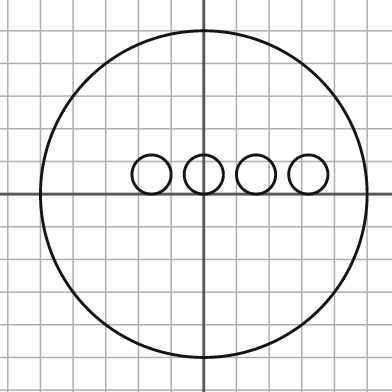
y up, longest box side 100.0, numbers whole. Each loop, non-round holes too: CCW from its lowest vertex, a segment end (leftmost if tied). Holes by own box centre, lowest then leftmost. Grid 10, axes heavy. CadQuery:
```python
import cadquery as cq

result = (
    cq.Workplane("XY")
    .moveTo(0.0, 0.0)
    .circle(50.0)
    .moveTo(-16.0, 6.0)
    .circle(6.0)
    .moveTo(0.0, 6.0)
    .circle(6.0)
    .moveTo(16.0, 6.0)
    .circle(6.0)
    .moveTo(32.0, 6.0)
    .circle(6.0)
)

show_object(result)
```